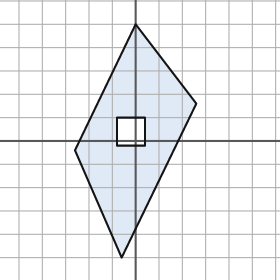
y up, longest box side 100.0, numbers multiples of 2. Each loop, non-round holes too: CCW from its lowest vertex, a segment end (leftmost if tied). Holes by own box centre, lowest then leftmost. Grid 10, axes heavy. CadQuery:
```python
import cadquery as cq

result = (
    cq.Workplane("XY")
    .moveTo(-6.0, -50.0)
    .lineTo(26.0, 16.0)
    .lineTo(0.0, 50.0)
    .lineTo(-26.0, -4.0)
    .close()
    .moveTo(-8.0, -2.0)
    .lineTo(4.0, -2.0)
    .lineTo(4.0, 10.0)
    .lineTo(-8.0, 10.0)
    .close()
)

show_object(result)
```